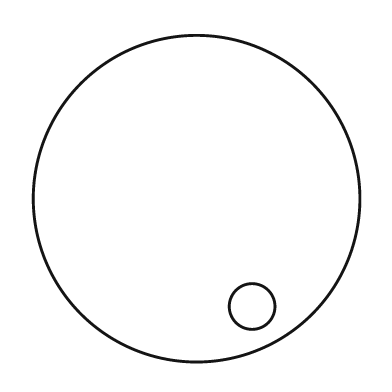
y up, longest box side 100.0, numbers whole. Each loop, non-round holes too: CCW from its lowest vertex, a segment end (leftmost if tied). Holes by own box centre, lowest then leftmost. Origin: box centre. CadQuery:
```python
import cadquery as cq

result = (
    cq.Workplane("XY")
    .moveTo(0.0, 0.0)
    .circle(50.0)
    .moveTo(17.0, -33.0)
    .circle(7.0)
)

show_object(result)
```